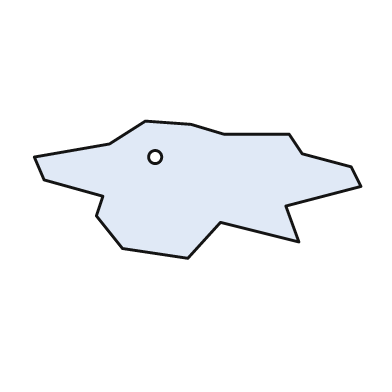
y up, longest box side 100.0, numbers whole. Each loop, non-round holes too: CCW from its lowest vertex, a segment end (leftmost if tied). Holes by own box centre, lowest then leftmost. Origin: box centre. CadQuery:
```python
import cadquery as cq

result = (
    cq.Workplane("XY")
    .moveTo(-3.0, -21.0)
    .lineTo(7.0, -10.0)
    .lineTo(31.0, -16.0)
    .lineTo(27.0, -5.0)
    .lineTo(50.0, 1.0)
    .lineTo(47.0, 7.0)
    .lineTo(32.0, 11.0)
    .lineTo(28.0, 17.0)
    .lineTo(8.0, 17.0)
    .lineTo(-2.0, 20.0)
    .lineTo(-16.0, 21.0)
    .lineTo(-27.0, 14.0)
    .lineTo(-50.0, 10.0)
    .lineTo(-47.0, 3.0)
    .lineTo(-29.0, -2.0)
    .lineTo(-31.0, -8.0)
    .lineTo(-23.0, -18.0)
    .close()
    .moveTo(-13.0, 10.0)
    .circle(2.0)
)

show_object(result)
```